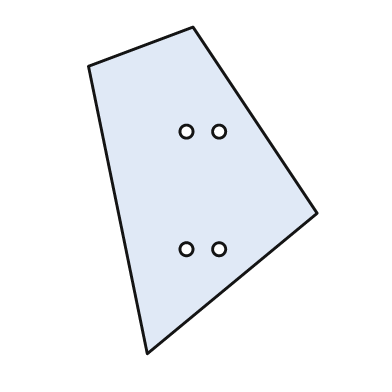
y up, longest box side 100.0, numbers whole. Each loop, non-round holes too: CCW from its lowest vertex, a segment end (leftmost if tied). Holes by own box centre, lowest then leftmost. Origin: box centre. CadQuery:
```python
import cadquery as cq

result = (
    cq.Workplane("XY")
    .moveTo(-17.0, -50.0)
    .lineTo(35.0, -7.0)
    .lineTo(-3.0, 50.0)
    .lineTo(-35.0, 38.0)
    .close()
    .moveTo(-5.0, -18.0)
    .circle(2.0)
    .moveTo(5.0, -18.0)
    .circle(2.0)
    .moveTo(-5.0, 18.0)
    .circle(2.0)
    .moveTo(5.0, 18.0)
    .circle(2.0)
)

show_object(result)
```